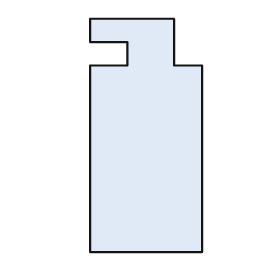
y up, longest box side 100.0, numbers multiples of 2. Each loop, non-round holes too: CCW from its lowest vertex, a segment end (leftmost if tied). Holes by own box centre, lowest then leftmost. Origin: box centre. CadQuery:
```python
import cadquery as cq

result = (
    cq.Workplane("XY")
    .moveTo(-24.0, -50.0)
    .lineTo(24.0, -50.0)
    .lineTo(24.0, 30.0)
    .lineTo(12.0, 30.0)
    .lineTo(12.0, 50.0)
    .lineTo(-24.0, 50.0)
    .lineTo(-24.0, 40.0)
    .lineTo(-8.0, 40.0)
    .lineTo(-8.0, 30.0)
    .lineTo(-24.0, 30.0)
    .close()
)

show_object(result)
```